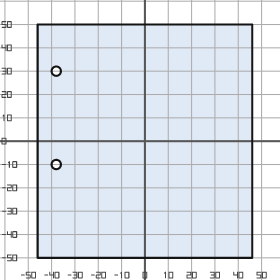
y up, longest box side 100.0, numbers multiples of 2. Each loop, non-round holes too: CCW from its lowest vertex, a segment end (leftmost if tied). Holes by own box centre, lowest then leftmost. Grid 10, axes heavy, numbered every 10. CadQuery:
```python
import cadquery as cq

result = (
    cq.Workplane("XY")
    .moveTo(-46.0, -50.0)
    .lineTo(46.0, -50.0)
    .lineTo(46.0, 50.0)
    .lineTo(-46.0, 50.0)
    .close()
    .moveTo(-38.0, -10.0)
    .circle(2.0)
    .moveTo(-38.0, 30.0)
    .circle(2.0)
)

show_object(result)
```